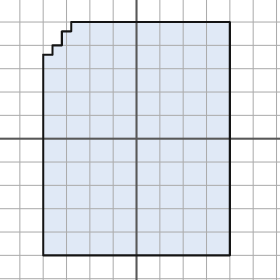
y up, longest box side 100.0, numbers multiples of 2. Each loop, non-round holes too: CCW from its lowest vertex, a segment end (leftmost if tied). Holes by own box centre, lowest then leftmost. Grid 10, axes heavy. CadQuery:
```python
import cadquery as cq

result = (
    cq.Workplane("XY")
    .moveTo(-40.0, -50.0)
    .lineTo(40.0, -50.0)
    .lineTo(40.0, 50.0)
    .lineTo(-28.0, 50.0)
    .lineTo(-28.0, 46.0)
    .lineTo(-32.0, 46.0)
    .lineTo(-32.0, 40.0)
    .lineTo(-36.0, 40.0)
    .lineTo(-36.0, 36.0)
    .lineTo(-40.0, 36.0)
    .close()
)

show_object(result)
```